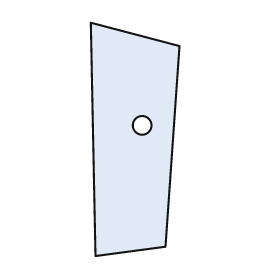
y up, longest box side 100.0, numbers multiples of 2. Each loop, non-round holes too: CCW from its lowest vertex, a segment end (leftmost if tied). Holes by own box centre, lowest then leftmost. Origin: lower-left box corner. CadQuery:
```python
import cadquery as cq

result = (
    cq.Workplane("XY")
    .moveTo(2.0, 0.0)
    .lineTo(32.0, 4.0)
    .lineTo(38.0, 90.0)
    .lineTo(0.0, 100.0)
    .close()
    .moveTo(22.0, 56.0)
    .circle(4.0)
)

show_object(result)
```